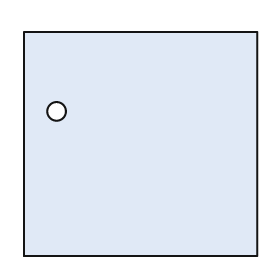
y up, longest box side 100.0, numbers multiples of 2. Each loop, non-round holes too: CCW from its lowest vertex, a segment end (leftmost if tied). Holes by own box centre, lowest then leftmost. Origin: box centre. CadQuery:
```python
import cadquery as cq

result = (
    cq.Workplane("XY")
    .moveTo(-50.0, -48.0)
    .lineTo(50.0, -48.0)
    .lineTo(50.0, 48.0)
    .lineTo(-50.0, 48.0)
    .close()
    .moveTo(-36.0, 14.0)
    .circle(4.0)
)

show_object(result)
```